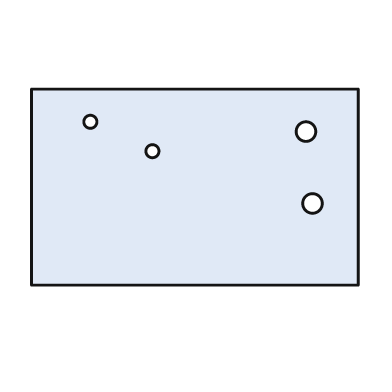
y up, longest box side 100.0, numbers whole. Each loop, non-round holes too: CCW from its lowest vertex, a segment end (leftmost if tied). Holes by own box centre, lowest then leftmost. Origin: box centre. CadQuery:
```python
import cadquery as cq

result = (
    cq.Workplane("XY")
    .moveTo(-50.0, -30.0)
    .lineTo(50.0, -30.0)
    .lineTo(50.0, 30.0)
    .lineTo(-50.0, 30.0)
    .close()
    .moveTo(36.0, -5.0)
    .circle(3.0)
    .moveTo(-13.0, 11.0)
    .circle(2.0)
    .moveTo(34.0, 17.0)
    .circle(3.0)
    .moveTo(-32.0, 20.0)
    .circle(2.0)
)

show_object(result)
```